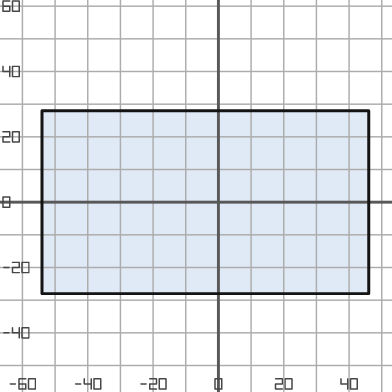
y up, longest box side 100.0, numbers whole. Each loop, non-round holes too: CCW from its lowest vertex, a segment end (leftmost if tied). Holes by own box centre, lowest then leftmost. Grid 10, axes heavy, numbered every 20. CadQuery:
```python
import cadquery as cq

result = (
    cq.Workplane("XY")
    .moveTo(-54.0, -28.0)
    .lineTo(46.0, -28.0)
    .lineTo(46.0, 28.0)
    .lineTo(-54.0, 28.0)
    .close()
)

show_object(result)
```